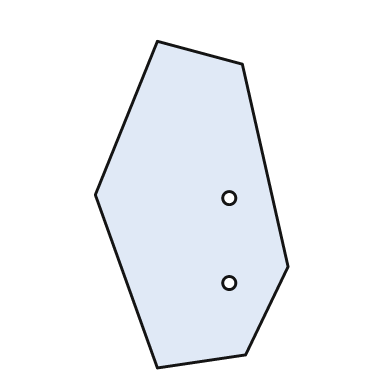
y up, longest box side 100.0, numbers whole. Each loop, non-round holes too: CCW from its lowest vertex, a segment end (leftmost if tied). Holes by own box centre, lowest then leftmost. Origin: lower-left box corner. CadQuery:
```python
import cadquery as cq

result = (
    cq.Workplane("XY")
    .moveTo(19.0, 0.0)
    .lineTo(46.0, 4.0)
    .lineTo(59.0, 31.0)
    .lineTo(45.0, 93.0)
    .lineTo(19.0, 100.0)
    .lineTo(0.0, 53.0)
    .close()
    .moveTo(41.0, 26.0)
    .circle(2.0)
    .moveTo(41.0, 52.0)
    .circle(2.0)
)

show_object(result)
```